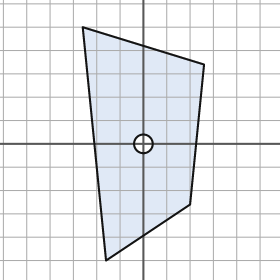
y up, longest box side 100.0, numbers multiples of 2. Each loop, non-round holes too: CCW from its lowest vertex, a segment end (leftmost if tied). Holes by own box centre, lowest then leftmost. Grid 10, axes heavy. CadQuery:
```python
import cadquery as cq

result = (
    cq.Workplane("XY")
    .moveTo(-16.0, -50.0)
    .lineTo(20.0, -26.0)
    .lineTo(26.0, 34.0)
    .lineTo(-26.0, 50.0)
    .close()
    .moveTo(0.0, 0.0)
    .circle(4.0)
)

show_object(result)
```